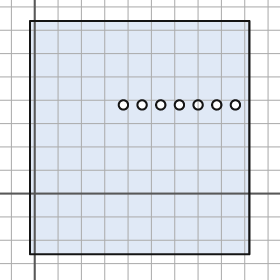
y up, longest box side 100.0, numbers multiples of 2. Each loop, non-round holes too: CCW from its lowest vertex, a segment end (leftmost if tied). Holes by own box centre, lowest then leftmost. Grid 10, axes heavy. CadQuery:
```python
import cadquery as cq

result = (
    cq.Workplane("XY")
    .moveTo(-2.0, -26.0)
    .lineTo(92.0, -26.0)
    .lineTo(92.0, 74.0)
    .lineTo(-2.0, 74.0)
    .close()
    .moveTo(38.0, 38.0)
    .circle(2.0)
    .moveTo(46.0, 38.0)
    .circle(2.0)
    .moveTo(54.0, 38.0)
    .circle(2.0)
    .moveTo(62.0, 38.0)
    .circle(2.0)
    .moveTo(70.0, 38.0)
    .circle(2.0)
    .moveTo(78.0, 38.0)
    .circle(2.0)
    .moveTo(86.0, 38.0)
    .circle(2.0)
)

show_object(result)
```